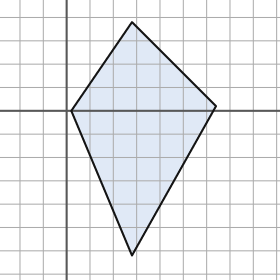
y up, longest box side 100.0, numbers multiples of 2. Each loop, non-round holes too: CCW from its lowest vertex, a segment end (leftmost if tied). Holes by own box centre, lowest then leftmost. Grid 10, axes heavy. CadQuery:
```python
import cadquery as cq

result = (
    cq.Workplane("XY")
    .moveTo(28.0, -62.0)
    .lineTo(64.0, 2.0)
    .lineTo(28.0, 38.0)
    .lineTo(2.0, 0.0)
    .close()
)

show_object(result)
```